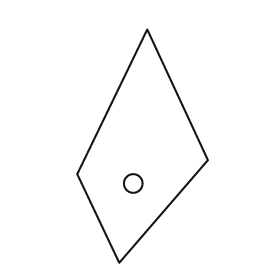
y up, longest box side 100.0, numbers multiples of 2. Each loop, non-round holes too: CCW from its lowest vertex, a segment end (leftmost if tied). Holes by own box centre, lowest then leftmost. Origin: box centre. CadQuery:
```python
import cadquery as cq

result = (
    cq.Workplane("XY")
    .moveTo(-10.0, -50.0)
    .lineTo(28.0, -6.0)
    .lineTo(2.0, 50.0)
    .lineTo(-28.0, -12.0)
    .close()
    .moveTo(-4.0, -16.0)
    .circle(4.0)
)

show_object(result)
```